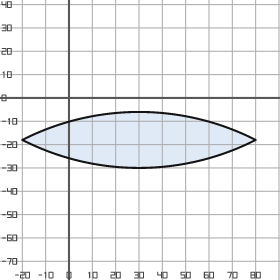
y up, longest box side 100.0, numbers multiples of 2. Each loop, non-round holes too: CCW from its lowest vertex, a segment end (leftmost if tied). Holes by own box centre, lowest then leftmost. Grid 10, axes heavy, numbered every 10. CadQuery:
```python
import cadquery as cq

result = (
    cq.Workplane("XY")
    .moveTo(-20.0, -18.0)
    .threePointArc((30.0, -30.0), (80.0, -18.0))
    .threePointArc((30.0, -6.0), (-20.0, -18.0))
    .close()
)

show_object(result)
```